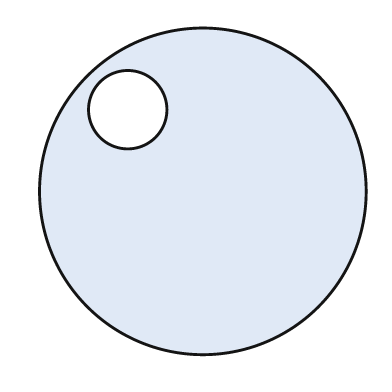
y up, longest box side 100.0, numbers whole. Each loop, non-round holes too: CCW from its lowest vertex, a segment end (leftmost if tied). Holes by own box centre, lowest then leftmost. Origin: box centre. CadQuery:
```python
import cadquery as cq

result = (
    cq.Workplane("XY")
    .moveTo(0.0, 0.0)
    .circle(50.0)
    .moveTo(-23.0, 25.0)
    .circle(12.0)
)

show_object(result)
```